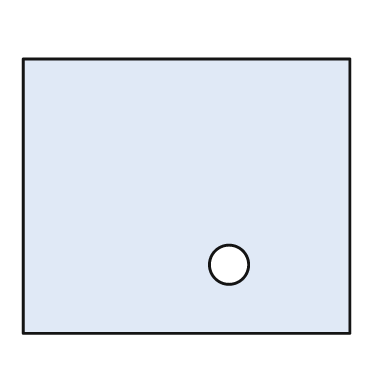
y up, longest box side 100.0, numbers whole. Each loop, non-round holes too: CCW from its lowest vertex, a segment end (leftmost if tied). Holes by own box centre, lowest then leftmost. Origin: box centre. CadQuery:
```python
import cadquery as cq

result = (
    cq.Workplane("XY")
    .moveTo(-50.0, -42.0)
    .lineTo(50.0, -42.0)
    .lineTo(50.0, 42.0)
    .lineTo(-50.0, 42.0)
    .close()
    .moveTo(13.0, -21.0)
    .circle(6.0)
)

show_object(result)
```